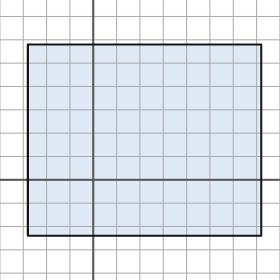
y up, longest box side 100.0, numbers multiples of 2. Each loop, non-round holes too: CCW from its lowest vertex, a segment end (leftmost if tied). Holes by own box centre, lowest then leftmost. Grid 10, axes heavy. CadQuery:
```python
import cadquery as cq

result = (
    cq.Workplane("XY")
    .moveTo(-28.0, -24.0)
    .lineTo(72.0, -24.0)
    .lineTo(72.0, 58.0)
    .lineTo(-28.0, 58.0)
    .close()
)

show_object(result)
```